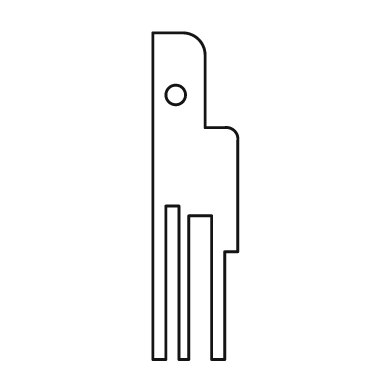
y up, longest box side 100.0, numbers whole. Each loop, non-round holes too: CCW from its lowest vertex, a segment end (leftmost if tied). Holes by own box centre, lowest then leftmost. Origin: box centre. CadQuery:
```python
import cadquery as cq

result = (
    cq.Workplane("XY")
    .moveTo(-13.0, -50.0)
    .lineTo(-9.0, -50.0)
    .lineTo(-9.0, -3.0)
    .lineTo(-5.0, -3.0)
    .lineTo(-5.0, -50.0)
    .lineTo(-2.0, -50.0)
    .lineTo(-2.0, -6.0)
    .lineTo(5.0, -6.0)
    .lineTo(5.0, -50.0)
    .lineTo(9.0, -50.0)
    .lineTo(9.0, -17.0)
    .lineTo(13.0, -17.0)
    .lineTo(13.0, 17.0)
    .threePointArc((12.0, 20.0), (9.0, 21.0))
    .lineTo(3.0, 21.0)
    .lineTo(3.0, 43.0)
    .threePointArc((1.0, 48.0), (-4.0, 50.0))
    .lineTo(-13.0, 50.0)
    .close()
    .moveTo(-6.0, 31.0)
    .circle(3.0)
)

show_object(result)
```